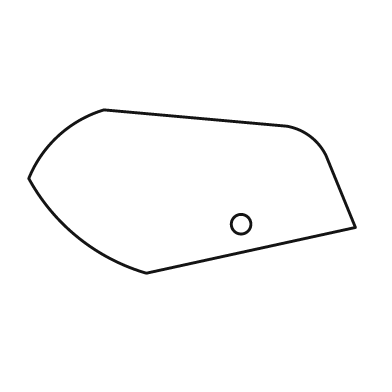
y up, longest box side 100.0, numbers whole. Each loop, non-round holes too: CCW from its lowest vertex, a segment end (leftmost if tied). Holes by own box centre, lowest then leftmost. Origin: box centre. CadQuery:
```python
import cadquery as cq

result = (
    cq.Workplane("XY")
    .moveTo(-14.0, -25.0)
    .lineTo(50.0, -11.0)
    .lineTo(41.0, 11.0)
    .threePointArc((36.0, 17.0), (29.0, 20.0))
    .lineTo(-27.0, 25.0)
    .threePointArc((-41.0, 17.0), (-50.0, 4.0))
    .threePointArc((-35.0, -14.0), (-14.0, -25.0))
    .close()
    .moveTo(15.0, -10.0)
    .circle(3.0)
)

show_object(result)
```